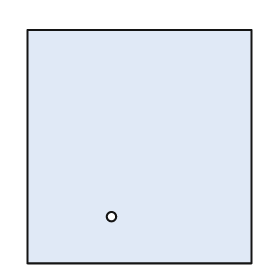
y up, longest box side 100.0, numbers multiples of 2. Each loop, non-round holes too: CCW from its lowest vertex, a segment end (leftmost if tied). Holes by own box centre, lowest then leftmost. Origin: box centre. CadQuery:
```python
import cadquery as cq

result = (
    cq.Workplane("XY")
    .moveTo(-48.0, -50.0)
    .lineTo(48.0, -50.0)
    .lineTo(48.0, 50.0)
    .lineTo(-48.0, 50.0)
    .close()
    .moveTo(-12.0, -30.0)
    .circle(2.0)
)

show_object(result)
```